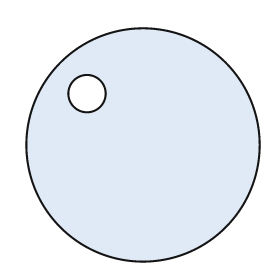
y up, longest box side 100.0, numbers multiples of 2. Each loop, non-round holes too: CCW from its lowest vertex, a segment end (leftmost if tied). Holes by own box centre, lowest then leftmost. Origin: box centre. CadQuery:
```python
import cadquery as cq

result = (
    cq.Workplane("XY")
    .moveTo(0.0, 0.0)
    .circle(50.0)
    .moveTo(-24.0, 22.0)
    .circle(8.0)
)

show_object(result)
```